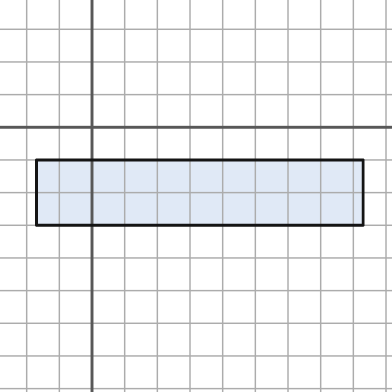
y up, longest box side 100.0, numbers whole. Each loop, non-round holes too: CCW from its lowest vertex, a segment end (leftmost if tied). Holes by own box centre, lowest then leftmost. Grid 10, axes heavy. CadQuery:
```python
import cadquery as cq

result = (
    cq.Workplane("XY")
    .moveTo(-17.0, -30.0)
    .lineTo(83.0, -30.0)
    .lineTo(83.0, -10.0)
    .lineTo(-17.0, -10.0)
    .close()
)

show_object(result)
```